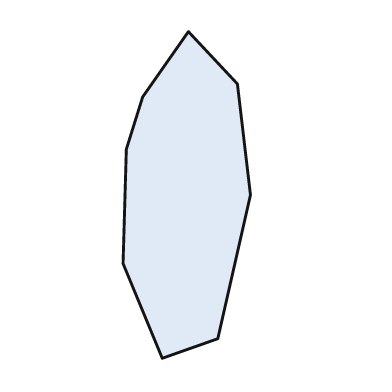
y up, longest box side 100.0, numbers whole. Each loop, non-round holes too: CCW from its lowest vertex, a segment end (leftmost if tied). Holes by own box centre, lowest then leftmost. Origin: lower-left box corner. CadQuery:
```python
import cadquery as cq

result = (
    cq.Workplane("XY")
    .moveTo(12.0, 0.0)
    .lineTo(29.0, 6.0)
    .lineTo(39.0, 50.0)
    .lineTo(35.0, 84.0)
    .lineTo(20.0, 100.0)
    .lineTo(6.0, 80.0)
    .lineTo(1.0, 64.0)
    .lineTo(0.0, 29.0)
    .close()
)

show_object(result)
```